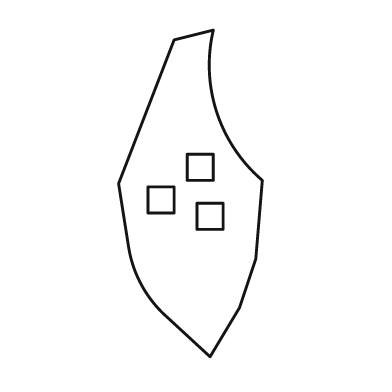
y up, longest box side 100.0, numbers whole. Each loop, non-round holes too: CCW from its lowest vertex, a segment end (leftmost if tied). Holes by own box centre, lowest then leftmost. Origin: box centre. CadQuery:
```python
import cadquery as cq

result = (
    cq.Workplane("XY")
    .moveTo(6.0, -50.0)
    .lineTo(15.0, -35.0)
    .lineTo(20.0, -20.0)
    .lineTo(22.0, 4.0)
    .threePointArc((8.0, 25.0), (7.0, 50.0))
    .lineTo(-5.0, 47.0)
    .lineTo(-22.0, 3.0)
    .lineTo(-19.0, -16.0)
    .threePointArc((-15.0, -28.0), (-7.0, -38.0))
    .close()
    .moveTo(2.0, -11.0)
    .lineTo(10.0, -11.0)
    .lineTo(10.0, -3.0)
    .lineTo(2.0, -3.0)
    .close()
    .moveTo(-13.0, -6.0)
    .lineTo(-5.0, -6.0)
    .lineTo(-5.0, 2.0)
    .lineTo(-13.0, 2.0)
    .close()
    .moveTo(-1.0, 4.0)
    .lineTo(7.0, 4.0)
    .lineTo(7.0, 12.0)
    .lineTo(-1.0, 12.0)
    .close()
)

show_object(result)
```